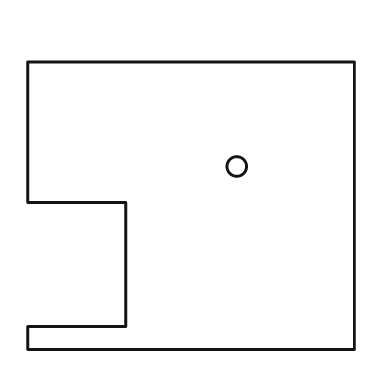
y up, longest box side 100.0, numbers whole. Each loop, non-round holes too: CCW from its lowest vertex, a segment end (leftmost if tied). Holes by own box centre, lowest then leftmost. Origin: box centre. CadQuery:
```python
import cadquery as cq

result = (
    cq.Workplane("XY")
    .moveTo(-50.0, -44.0)
    .lineTo(50.0, -44.0)
    .lineTo(50.0, 44.0)
    .lineTo(-50.0, 44.0)
    .lineTo(-50.0, 1.0)
    .lineTo(-20.0, 1.0)
    .lineTo(-20.0, -37.0)
    .lineTo(-50.0, -37.0)
    .close()
    .moveTo(14.0, 12.0)
    .circle(3.0)
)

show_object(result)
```